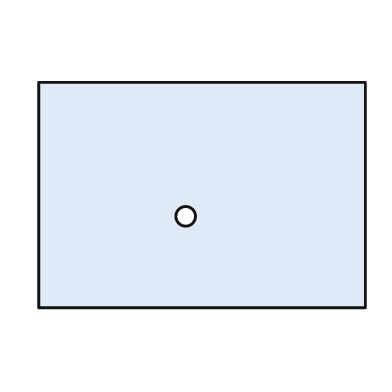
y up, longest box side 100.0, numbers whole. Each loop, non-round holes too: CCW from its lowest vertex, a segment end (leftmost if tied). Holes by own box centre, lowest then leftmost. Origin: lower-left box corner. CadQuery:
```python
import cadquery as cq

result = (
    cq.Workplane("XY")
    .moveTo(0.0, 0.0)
    .lineTo(100.0, 0.0)
    .lineTo(100.0, 69.0)
    .lineTo(0.0, 69.0)
    .close()
    .moveTo(45.0, 28.0)
    .circle(3.0)
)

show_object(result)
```